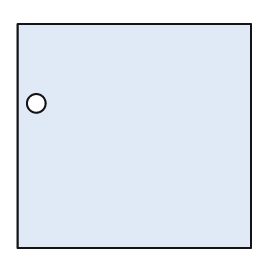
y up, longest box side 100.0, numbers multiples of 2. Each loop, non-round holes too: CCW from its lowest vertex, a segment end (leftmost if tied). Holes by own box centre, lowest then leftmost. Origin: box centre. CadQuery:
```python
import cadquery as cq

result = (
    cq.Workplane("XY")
    .moveTo(-50.0, -48.0)
    .lineTo(50.0, -48.0)
    .lineTo(50.0, 48.0)
    .lineTo(-50.0, 48.0)
    .close()
    .moveTo(-42.0, 14.0)
    .circle(4.0)
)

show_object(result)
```